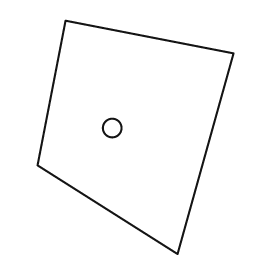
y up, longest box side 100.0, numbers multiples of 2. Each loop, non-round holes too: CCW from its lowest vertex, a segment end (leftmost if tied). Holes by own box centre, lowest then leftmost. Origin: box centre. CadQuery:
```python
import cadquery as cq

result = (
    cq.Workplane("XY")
    .moveTo(18.0, -50.0)
    .lineTo(42.0, 36.0)
    .lineTo(-30.0, 50.0)
    .lineTo(-42.0, -12.0)
    .close()
    .moveTo(-10.0, 4.0)
    .circle(4.0)
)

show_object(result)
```